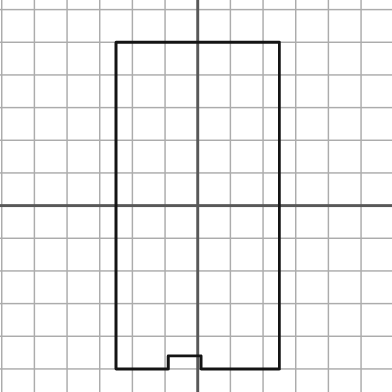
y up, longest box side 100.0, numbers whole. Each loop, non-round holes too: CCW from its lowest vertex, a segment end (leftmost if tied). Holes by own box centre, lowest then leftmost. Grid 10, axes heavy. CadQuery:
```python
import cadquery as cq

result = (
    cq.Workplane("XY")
    .moveTo(-25.0, -50.0)
    .lineTo(-9.0, -50.0)
    .lineTo(-9.0, -46.0)
    .lineTo(1.0, -46.0)
    .lineTo(1.0, -50.0)
    .lineTo(25.0, -50.0)
    .lineTo(25.0, 50.0)
    .lineTo(-25.0, 50.0)
    .close()
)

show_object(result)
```